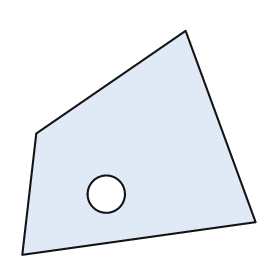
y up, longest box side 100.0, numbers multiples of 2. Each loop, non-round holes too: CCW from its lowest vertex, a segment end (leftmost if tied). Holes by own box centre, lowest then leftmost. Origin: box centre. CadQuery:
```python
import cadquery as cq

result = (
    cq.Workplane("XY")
    .moveTo(-50.0, -48.0)
    .lineTo(50.0, -34.0)
    .lineTo(20.0, 48.0)
    .lineTo(-44.0, 4.0)
    .close()
    .moveTo(-14.0, -22.0)
    .circle(8.0)
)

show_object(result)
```